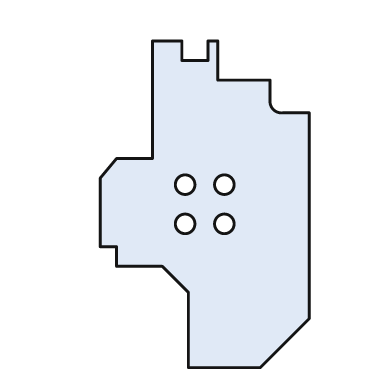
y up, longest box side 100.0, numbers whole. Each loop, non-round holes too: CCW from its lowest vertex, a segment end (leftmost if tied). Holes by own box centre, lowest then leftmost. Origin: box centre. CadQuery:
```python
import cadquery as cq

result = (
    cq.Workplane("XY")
    .moveTo(-5.0, -50.0)
    .lineTo(17.0, -50.0)
    .lineTo(32.0, -35.0)
    .lineTo(32.0, 28.0)
    .lineTo(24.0, 28.0)
    .threePointArc((21.0, 29.0), (20.0, 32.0))
    .lineTo(20.0, 38.0)
    .lineTo(4.0, 38.0)
    .lineTo(4.0, 50.0)
    .lineTo(1.0, 50.0)
    .lineTo(1.0, 44.0)
    .lineTo(-7.0, 44.0)
    .lineTo(-7.0, 50.0)
    .lineTo(-16.0, 50.0)
    .lineTo(-16.0, 14.0)
    .lineTo(-27.0, 14.0)
    .lineTo(-32.0, 8.0)
    .lineTo(-32.0, -13.0)
    .lineTo(-27.0, -13.0)
    .lineTo(-27.0, -19.0)
    .lineTo(-13.0, -19.0)
    .lineTo(-5.0, -27.0)
    .close()
    .moveTo(-6.0, -6.0)
    .circle(3.0)
    .moveTo(6.0, -6.0)
    .circle(3.0)
    .moveTo(-6.0, 6.0)
    .circle(3.0)
    .moveTo(6.0, 6.0)
    .circle(3.0)
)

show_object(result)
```